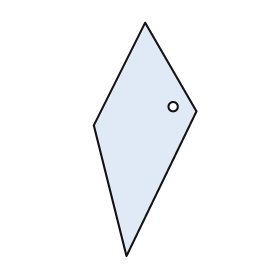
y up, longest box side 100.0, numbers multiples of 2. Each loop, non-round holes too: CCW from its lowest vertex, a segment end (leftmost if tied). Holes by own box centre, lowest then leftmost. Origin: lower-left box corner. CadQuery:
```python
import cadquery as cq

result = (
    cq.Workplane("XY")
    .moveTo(14.0, 0.0)
    .lineTo(44.0, 62.0)
    .lineTo(22.0, 100.0)
    .lineTo(0.0, 56.0)
    .close()
    .moveTo(34.0, 64.0)
    .circle(2.0)
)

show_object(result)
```